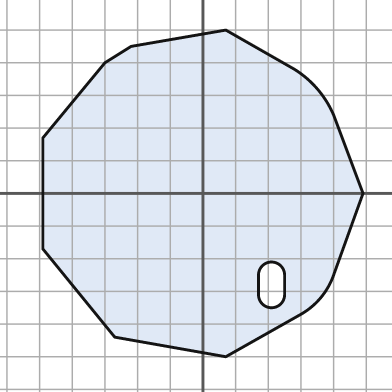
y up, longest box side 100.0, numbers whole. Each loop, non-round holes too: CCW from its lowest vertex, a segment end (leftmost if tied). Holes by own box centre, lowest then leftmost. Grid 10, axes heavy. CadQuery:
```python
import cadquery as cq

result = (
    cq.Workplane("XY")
    .moveTo(7.0, -50.0)
    .lineTo(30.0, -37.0)
    .threePointArc((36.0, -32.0), (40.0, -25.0))
    .lineTo(49.0, 0.0)
    .lineTo(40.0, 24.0)
    .threePointArc((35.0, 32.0), (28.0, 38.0))
    .lineTo(7.0, 50.0)
    .lineTo(-22.0, 45.0)
    .lineTo(-30.0, 40.0)
    .lineTo(-49.0, 17.0)
    .lineTo(-49.0, -17.0)
    .lineTo(-27.0, -44.0)
    .close()
    .moveTo(17.0, -31.0)
    .threePointArc((21.0, -35.0), (25.0, -31.0))
    .lineTo(25.0, -25.0)
    .threePointArc((21.0, -21.0), (17.0, -25.0))
    .close()
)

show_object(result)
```